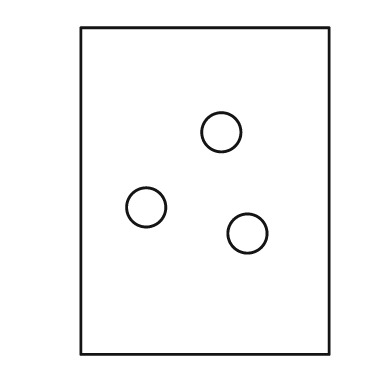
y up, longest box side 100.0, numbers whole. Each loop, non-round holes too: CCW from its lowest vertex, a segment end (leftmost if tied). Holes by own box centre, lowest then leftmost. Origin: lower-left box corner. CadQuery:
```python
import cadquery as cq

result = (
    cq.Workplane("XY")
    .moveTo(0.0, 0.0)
    .lineTo(76.0, 0.0)
    .lineTo(76.0, 100.0)
    .lineTo(0.0, 100.0)
    .close()
    .moveTo(51.0, 37.0)
    .circle(6.0)
    .moveTo(20.0, 45.0)
    .circle(6.0)
    .moveTo(43.0, 68.0)
    .circle(6.0)
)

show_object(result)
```